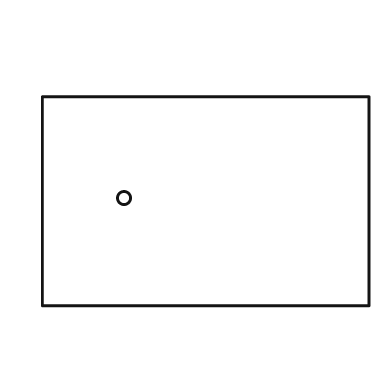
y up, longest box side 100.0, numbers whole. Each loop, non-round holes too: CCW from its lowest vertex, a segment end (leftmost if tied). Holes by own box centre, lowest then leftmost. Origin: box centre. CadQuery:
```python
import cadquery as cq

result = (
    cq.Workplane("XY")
    .moveTo(-50.0, -32.0)
    .lineTo(50.0, -32.0)
    .lineTo(50.0, 32.0)
    .lineTo(-50.0, 32.0)
    .close()
    .moveTo(-25.0, 1.0)
    .circle(2.0)
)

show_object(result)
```